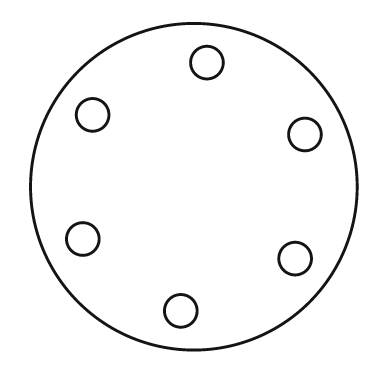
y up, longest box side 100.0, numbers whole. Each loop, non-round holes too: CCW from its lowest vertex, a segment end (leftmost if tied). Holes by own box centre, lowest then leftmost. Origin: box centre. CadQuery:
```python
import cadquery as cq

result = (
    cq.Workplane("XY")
    .moveTo(0.0, 0.0)
    .circle(50.0)
    .moveTo(-4.0, -38.0)
    .circle(5.0)
    .moveTo(31.0, -22.0)
    .circle(5.0)
    .moveTo(-34.0, -16.0)
    .circle(5.0)
    .moveTo(34.0, 16.0)
    .circle(5.0)
    .moveTo(-31.0, 22.0)
    .circle(5.0)
    .moveTo(4.0, 38.0)
    .circle(5.0)
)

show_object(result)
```